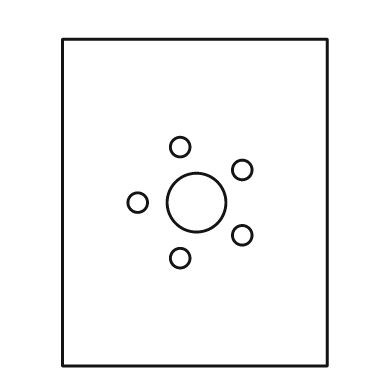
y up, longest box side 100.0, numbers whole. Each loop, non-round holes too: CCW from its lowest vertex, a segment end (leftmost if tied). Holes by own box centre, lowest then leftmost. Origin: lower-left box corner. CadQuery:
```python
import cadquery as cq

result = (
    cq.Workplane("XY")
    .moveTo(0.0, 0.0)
    .lineTo(81.0, 0.0)
    .lineTo(81.0, 100.0)
    .lineTo(0.0, 100.0)
    .close()
    .moveTo(36.0, 33.0)
    .circle(3.0)
    .moveTo(55.0, 40.0)
    .circle(3.0)
    .moveTo(23.0, 50.0)
    .circle(3.0)
    .moveTo(41.0, 50.0)
    .circle(9.0)
    .moveTo(55.0, 60.0)
    .circle(3.0)
    .moveTo(36.0, 67.0)
    .circle(3.0)
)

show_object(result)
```